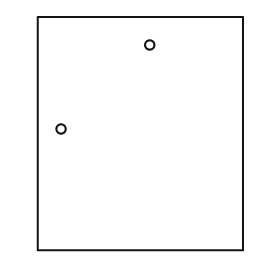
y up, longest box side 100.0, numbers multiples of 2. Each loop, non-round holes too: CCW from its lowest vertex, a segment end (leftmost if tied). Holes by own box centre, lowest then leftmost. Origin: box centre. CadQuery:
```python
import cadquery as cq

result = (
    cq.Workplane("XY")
    .moveTo(-44.0, -50.0)
    .lineTo(44.0, -50.0)
    .lineTo(44.0, 50.0)
    .lineTo(-44.0, 50.0)
    .close()
    .moveTo(-34.0, 2.0)
    .circle(2.0)
    .moveTo(4.0, 38.0)
    .circle(2.0)
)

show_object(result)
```